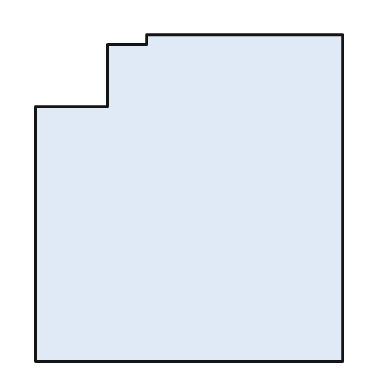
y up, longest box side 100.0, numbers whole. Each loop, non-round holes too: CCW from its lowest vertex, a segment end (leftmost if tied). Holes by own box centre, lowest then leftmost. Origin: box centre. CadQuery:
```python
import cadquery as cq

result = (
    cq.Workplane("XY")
    .moveTo(-47.0, -50.0)
    .lineTo(47.0, -50.0)
    .lineTo(47.0, 50.0)
    .lineTo(-13.0, 50.0)
    .lineTo(-13.0, 47.0)
    .lineTo(-25.0, 47.0)
    .lineTo(-25.0, 28.0)
    .lineTo(-47.0, 28.0)
    .close()
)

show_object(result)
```